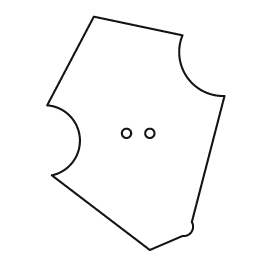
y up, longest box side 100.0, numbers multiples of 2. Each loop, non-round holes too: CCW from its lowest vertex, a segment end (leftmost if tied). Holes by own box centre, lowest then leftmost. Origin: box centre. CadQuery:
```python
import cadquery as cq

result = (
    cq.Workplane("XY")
    .moveTo(6.0, -50.0)
    .lineTo(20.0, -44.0)
    .threePointArc((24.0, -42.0), (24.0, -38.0))
    .lineTo(38.0, 16.0)
    .threePointArc((22.0, 24.0), (20.0, 42.0))
    .lineTo(-18.0, 50.0)
    .lineTo(-38.0, 12.0)
    .threePointArc((-24.0, -2.0), (-36.0, -18.0))
    .close()
    .moveTo(-4.0, 0.0)
    .circle(2.0)
    .moveTo(6.0, 0.0)
    .circle(2.0)
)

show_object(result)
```